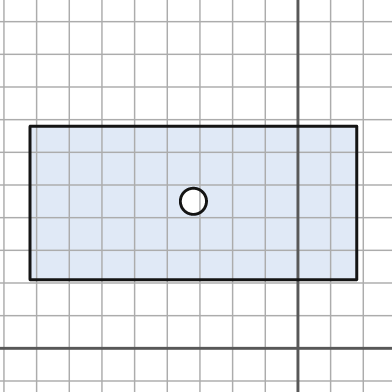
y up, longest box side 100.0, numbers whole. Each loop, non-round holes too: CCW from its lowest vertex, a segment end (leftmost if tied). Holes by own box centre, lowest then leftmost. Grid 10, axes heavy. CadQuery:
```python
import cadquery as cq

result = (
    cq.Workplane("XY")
    .moveTo(-82.0, 21.0)
    .lineTo(18.0, 21.0)
    .lineTo(18.0, 68.0)
    .lineTo(-82.0, 68.0)
    .close()
    .moveTo(-32.0, 45.0)
    .circle(4.0)
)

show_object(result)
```